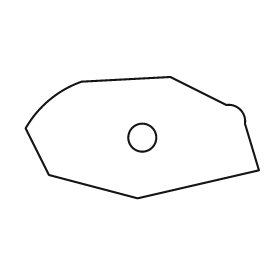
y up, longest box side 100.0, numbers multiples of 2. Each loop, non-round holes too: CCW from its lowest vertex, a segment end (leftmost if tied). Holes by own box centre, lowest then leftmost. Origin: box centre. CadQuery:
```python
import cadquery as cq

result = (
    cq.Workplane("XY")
    .moveTo(-2.0, -26.0)
    .lineTo(50.0, -14.0)
    .lineTo(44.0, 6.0)
    .threePointArc((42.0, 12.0), (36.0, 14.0))
    .lineTo(12.0, 26.0)
    .lineTo(-26.0, 24.0)
    .threePointArc((-40.0, 16.0), (-50.0, 4.0))
    .lineTo(-40.0, -16.0)
    .close()
    .moveTo(0.0, 0.0)
    .circle(6.0)
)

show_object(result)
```